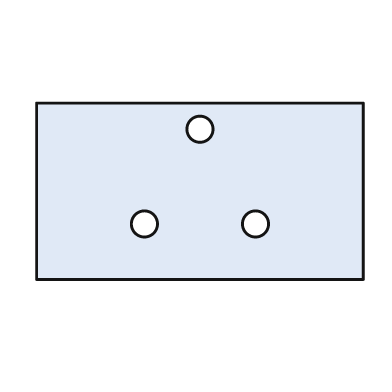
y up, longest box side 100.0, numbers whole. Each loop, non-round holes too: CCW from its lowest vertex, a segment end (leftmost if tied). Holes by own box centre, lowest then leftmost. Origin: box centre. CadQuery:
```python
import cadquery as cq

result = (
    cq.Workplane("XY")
    .moveTo(-50.0, -27.0)
    .lineTo(50.0, -27.0)
    .lineTo(50.0, 27.0)
    .lineTo(-50.0, 27.0)
    .close()
    .moveTo(-17.0, -10.0)
    .circle(4.0)
    .moveTo(17.0, -10.0)
    .circle(4.0)
    .moveTo(0.0, 19.0)
    .circle(4.0)
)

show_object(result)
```